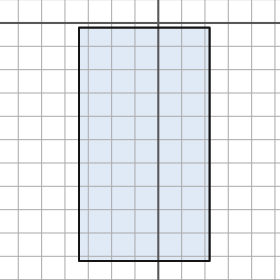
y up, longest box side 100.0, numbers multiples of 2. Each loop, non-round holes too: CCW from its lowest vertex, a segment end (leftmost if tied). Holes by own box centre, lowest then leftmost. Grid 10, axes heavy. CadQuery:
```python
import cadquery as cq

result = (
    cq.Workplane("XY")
    .moveTo(-34.0, -102.0)
    .lineTo(22.0, -102.0)
    .lineTo(22.0, -2.0)
    .lineTo(-34.0, -2.0)
    .close()
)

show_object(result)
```